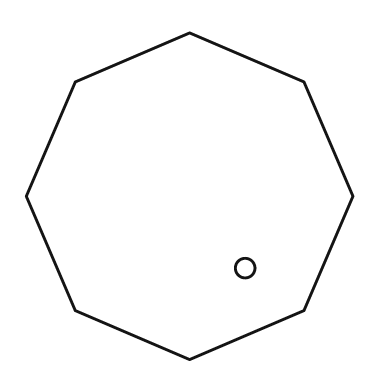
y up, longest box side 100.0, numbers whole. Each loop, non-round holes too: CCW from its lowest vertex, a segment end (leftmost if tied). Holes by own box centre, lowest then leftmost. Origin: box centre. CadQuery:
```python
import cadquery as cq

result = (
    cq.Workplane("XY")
    .moveTo(0.0, -50.0)
    .lineTo(35.0, -35.0)
    .lineTo(50.0, 0.0)
    .lineTo(35.0, 35.0)
    .lineTo(0.0, 50.0)
    .lineTo(-35.0, 35.0)
    .lineTo(-50.0, 0.0)
    .lineTo(-35.0, -35.0)
    .close()
    .moveTo(17.0, -22.0)
    .circle(3.0)
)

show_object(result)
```